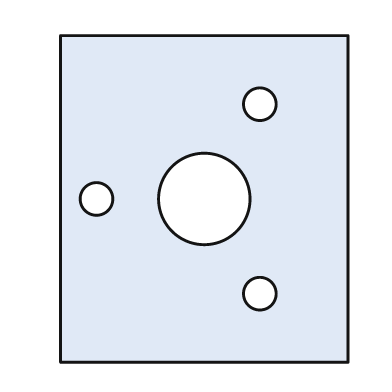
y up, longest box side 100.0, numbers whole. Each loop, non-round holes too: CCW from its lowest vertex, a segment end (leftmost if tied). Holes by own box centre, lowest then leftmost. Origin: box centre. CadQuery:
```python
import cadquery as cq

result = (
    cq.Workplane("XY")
    .moveTo(-44.0, -50.0)
    .lineTo(44.0, -50.0)
    .lineTo(44.0, 50.0)
    .lineTo(-44.0, 50.0)
    .close()
    .moveTo(17.0, -29.0)
    .circle(5.0)
    .moveTo(-33.0, 0.0)
    .circle(5.0)
    .moveTo(0.0, 0.0)
    .circle(14.0)
    .moveTo(17.0, 29.0)
    .circle(5.0)
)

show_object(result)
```